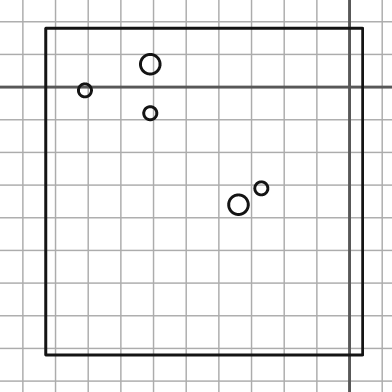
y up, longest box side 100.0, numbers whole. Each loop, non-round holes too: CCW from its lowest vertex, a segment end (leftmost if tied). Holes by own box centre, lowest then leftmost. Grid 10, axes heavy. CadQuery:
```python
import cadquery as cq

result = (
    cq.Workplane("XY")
    .moveTo(-93.0, -82.0)
    .lineTo(4.0, -82.0)
    .lineTo(4.0, 18.0)
    .lineTo(-93.0, 18.0)
    .close()
    .moveTo(-34.0, -36.0)
    .circle(3.0)
    .moveTo(-27.0, -31.0)
    .circle(2.0)
    .moveTo(-61.0, -8.0)
    .circle(2.0)
    .moveTo(-81.0, -1.0)
    .circle(2.0)
    .moveTo(-61.0, 7.0)
    .circle(3.0)
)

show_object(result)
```